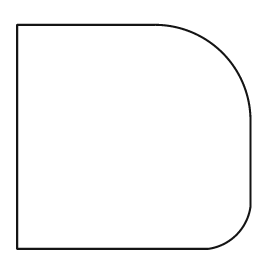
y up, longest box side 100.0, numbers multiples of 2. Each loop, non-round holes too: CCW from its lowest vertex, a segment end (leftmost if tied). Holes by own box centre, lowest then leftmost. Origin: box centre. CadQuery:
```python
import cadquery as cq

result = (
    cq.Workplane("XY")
    .moveTo(-50.0, -48.0)
    .lineTo(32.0, -48.0)
    .threePointArc((44.0, -42.0), (50.0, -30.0))
    .lineTo(50.0, 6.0)
    .threePointArc((38.0, 36.0), (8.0, 48.0))
    .lineTo(-50.0, 48.0)
    .close()
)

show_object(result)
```